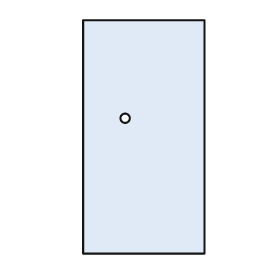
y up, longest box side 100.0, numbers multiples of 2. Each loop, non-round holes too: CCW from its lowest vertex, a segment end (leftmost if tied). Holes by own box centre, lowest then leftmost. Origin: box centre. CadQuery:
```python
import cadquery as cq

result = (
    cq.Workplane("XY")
    .moveTo(-26.0, -50.0)
    .lineTo(26.0, -50.0)
    .lineTo(26.0, 50.0)
    .lineTo(-26.0, 50.0)
    .close()
    .moveTo(-8.0, 8.0)
    .circle(2.0)
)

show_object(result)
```